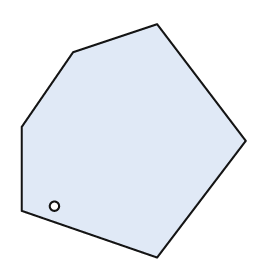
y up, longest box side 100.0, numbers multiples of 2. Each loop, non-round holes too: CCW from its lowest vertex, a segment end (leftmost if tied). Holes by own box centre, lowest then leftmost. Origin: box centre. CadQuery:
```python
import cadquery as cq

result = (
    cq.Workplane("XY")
    .moveTo(10.0, -50.0)
    .lineTo(48.0, 0.0)
    .lineTo(10.0, 50.0)
    .lineTo(-26.0, 38.0)
    .lineTo(-48.0, 6.0)
    .lineTo(-48.0, -30.0)
    .close()
    .moveTo(-34.0, -28.0)
    .circle(2.0)
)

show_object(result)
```